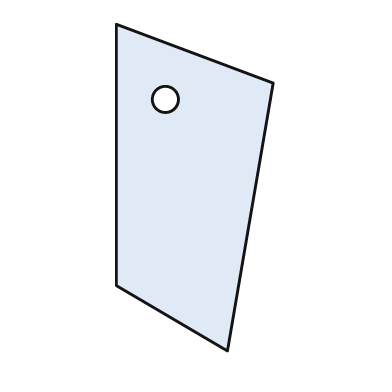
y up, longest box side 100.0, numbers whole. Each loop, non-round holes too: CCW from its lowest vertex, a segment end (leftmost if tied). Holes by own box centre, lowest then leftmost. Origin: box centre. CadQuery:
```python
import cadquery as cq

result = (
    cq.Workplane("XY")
    .moveTo(10.0, -50.0)
    .lineTo(24.0, 32.0)
    .lineTo(-24.0, 50.0)
    .lineTo(-24.0, -30.0)
    .close()
    .moveTo(-9.0, 27.0)
    .circle(4.0)
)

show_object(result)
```